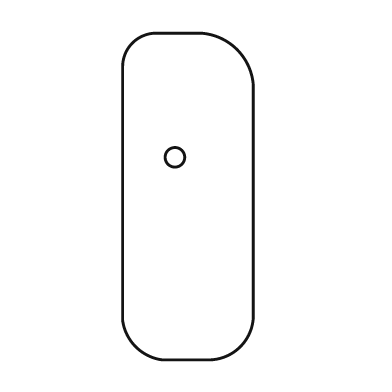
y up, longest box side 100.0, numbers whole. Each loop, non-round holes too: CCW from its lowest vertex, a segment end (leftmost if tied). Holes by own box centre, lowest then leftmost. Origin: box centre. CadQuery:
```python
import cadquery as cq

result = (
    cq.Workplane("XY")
    .moveTo(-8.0, -50.0)
    .lineTo(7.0, -50.0)
    .threePointArc((16.0, -46.0), (20.0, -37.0))
    .lineTo(20.0, 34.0)
    .threePointArc((15.0, 45.0), (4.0, 50.0))
    .lineTo(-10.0, 50.0)
    .threePointArc((-17.0, 47.0), (-20.0, 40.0))
    .lineTo(-20.0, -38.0)
    .threePointArc((-16.0, -46.0), (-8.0, -50.0))
    .close()
    .moveTo(-4.0, 12.0)
    .circle(3.0)
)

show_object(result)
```